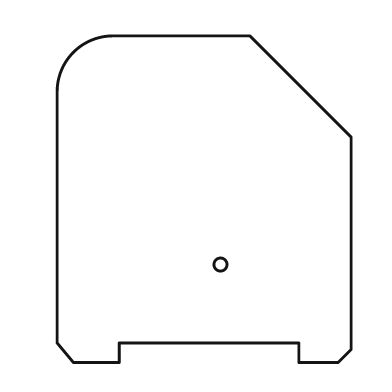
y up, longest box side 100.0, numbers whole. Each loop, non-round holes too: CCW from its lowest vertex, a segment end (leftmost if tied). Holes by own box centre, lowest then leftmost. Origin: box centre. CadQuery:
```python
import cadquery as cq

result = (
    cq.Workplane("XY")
    .moveTo(-40.0, -50.0)
    .lineTo(-26.0, -50.0)
    .lineTo(-26.0, -44.0)
    .lineTo(29.0, -44.0)
    .lineTo(29.0, -50.0)
    .lineTo(41.0, -50.0)
    .lineTo(45.0, -46.0)
    .lineTo(45.0, 19.0)
    .lineTo(14.0, 50.0)
    .lineTo(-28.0, 50.0)
    .threePointArc((-40.0, 45.0), (-45.0, 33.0))
    .lineTo(-45.0, -44.0)
    .close()
    .moveTo(5.0, -20.0)
    .circle(2.0)
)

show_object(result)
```